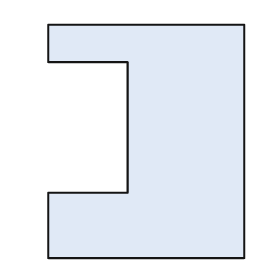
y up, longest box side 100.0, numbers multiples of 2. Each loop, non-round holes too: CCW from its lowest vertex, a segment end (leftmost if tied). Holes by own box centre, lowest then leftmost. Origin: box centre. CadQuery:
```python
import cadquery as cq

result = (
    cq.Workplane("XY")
    .moveTo(-42.0, -50.0)
    .lineTo(42.0, -50.0)
    .lineTo(42.0, 50.0)
    .lineTo(-42.0, 50.0)
    .lineTo(-42.0, 34.0)
    .lineTo(-8.0, 34.0)
    .lineTo(-8.0, -22.0)
    .lineTo(-42.0, -22.0)
    .close()
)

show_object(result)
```